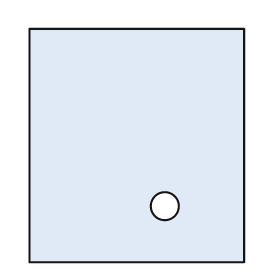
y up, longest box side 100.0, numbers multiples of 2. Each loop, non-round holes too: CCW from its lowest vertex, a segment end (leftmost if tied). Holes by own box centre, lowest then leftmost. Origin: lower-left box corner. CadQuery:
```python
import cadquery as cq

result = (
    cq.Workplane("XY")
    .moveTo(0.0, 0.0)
    .lineTo(92.0, 0.0)
    .lineTo(92.0, 100.0)
    .lineTo(0.0, 100.0)
    .close()
    .moveTo(58.0, 24.0)
    .circle(6.0)
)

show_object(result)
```